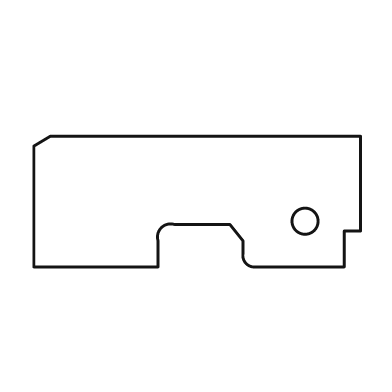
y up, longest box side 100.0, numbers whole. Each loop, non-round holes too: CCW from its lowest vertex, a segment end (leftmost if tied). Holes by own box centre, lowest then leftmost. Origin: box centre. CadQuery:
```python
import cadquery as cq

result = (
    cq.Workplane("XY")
    .moveTo(-50.0, -20.0)
    .lineTo(-12.0, -20.0)
    .lineTo(-12.0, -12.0)
    .threePointArc((-11.0, -8.0), (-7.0, -7.0))
    .lineTo(10.0, -7.0)
    .lineTo(14.0, -12.0)
    .lineTo(14.0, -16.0)
    .threePointArc((15.0, -19.0), (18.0, -20.0))
    .lineTo(45.0, -20.0)
    .lineTo(45.0, -9.0)
    .lineTo(50.0, -9.0)
    .lineTo(50.0, 20.0)
    .lineTo(-45.0, 20.0)
    .lineTo(-50.0, 17.0)
    .close()
    .moveTo(33.0, -6.0)
    .circle(4.0)
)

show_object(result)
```